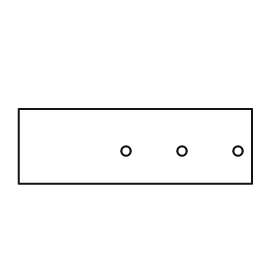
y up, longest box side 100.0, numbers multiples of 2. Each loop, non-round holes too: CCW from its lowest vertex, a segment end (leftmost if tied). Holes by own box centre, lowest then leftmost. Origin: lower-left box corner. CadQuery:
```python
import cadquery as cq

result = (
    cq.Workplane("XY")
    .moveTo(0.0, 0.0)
    .lineTo(100.0, 0.0)
    .lineTo(100.0, 32.0)
    .lineTo(0.0, 32.0)
    .close()
    .moveTo(46.0, 14.0)
    .circle(2.0)
    .moveTo(70.0, 14.0)
    .circle(2.0)
    .moveTo(94.0, 14.0)
    .circle(2.0)
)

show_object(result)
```